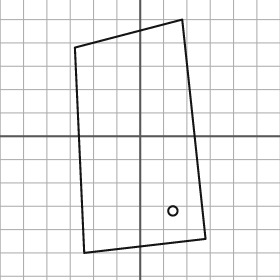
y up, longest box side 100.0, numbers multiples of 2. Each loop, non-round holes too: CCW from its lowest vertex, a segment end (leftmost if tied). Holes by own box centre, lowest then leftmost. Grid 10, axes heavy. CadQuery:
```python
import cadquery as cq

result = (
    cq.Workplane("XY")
    .moveTo(-24.0, -50.0)
    .lineTo(28.0, -44.0)
    .lineTo(18.0, 50.0)
    .lineTo(-28.0, 38.0)
    .close()
    .moveTo(14.0, -32.0)
    .circle(2.0)
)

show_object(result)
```